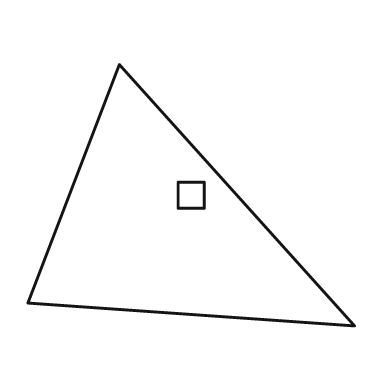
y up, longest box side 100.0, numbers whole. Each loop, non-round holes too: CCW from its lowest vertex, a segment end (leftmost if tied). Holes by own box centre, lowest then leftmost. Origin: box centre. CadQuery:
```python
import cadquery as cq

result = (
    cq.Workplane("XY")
    .moveTo(50.0, -40.0)
    .lineTo(-22.0, 40.0)
    .lineTo(-50.0, -33.0)
    .close()
    .moveTo(-4.0, -4.0)
    .lineTo(4.0, -4.0)
    .lineTo(4.0, 4.0)
    .lineTo(-4.0, 4.0)
    .close()
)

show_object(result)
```